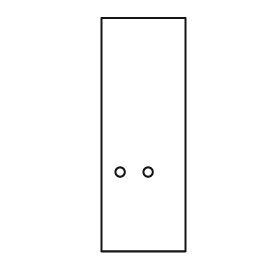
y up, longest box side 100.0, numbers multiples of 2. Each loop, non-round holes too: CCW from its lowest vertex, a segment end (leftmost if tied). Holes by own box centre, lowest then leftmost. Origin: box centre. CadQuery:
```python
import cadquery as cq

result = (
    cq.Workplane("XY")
    .moveTo(-18.0, -50.0)
    .lineTo(18.0, -50.0)
    .lineTo(18.0, 50.0)
    .lineTo(-18.0, 50.0)
    .close()
    .moveTo(-10.0, -16.0)
    .circle(2.0)
    .moveTo(2.0, -16.0)
    .circle(2.0)
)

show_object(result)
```